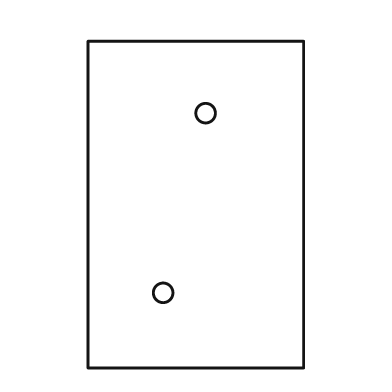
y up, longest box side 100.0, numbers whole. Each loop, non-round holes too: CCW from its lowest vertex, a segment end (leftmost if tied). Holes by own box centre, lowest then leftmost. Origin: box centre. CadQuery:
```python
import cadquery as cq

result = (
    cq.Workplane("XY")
    .moveTo(-33.0, -50.0)
    .lineTo(33.0, -50.0)
    .lineTo(33.0, 50.0)
    .lineTo(-33.0, 50.0)
    .close()
    .moveTo(-10.0, -27.0)
    .circle(3.0)
    .moveTo(3.0, 28.0)
    .circle(3.0)
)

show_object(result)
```